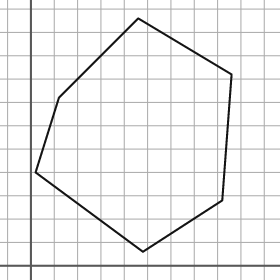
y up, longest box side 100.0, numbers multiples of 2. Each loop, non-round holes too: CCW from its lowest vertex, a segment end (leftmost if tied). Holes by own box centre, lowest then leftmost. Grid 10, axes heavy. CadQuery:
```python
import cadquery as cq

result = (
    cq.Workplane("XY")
    .moveTo(48.0, 6.0)
    .lineTo(82.0, 28.0)
    .lineTo(86.0, 82.0)
    .lineTo(46.0, 106.0)
    .lineTo(12.0, 72.0)
    .lineTo(2.0, 40.0)
    .close()
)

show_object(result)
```